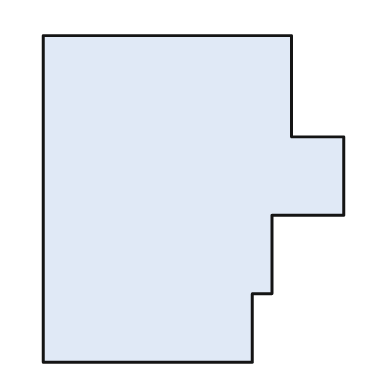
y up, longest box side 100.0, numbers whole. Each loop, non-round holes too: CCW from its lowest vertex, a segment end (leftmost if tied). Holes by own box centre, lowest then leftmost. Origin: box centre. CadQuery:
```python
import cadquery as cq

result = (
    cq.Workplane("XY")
    .moveTo(-46.0, -50.0)
    .lineTo(18.0, -50.0)
    .lineTo(18.0, -29.0)
    .lineTo(24.0, -29.0)
    .lineTo(24.0, -5.0)
    .lineTo(46.0, -5.0)
    .lineTo(46.0, 19.0)
    .lineTo(30.0, 19.0)
    .lineTo(30.0, 50.0)
    .lineTo(-46.0, 50.0)
    .close()
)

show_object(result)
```